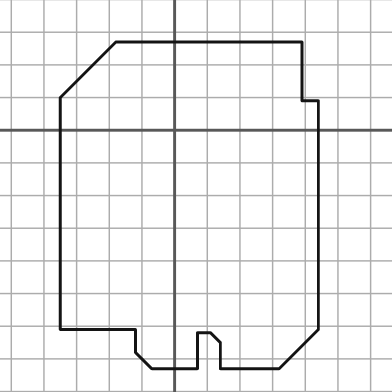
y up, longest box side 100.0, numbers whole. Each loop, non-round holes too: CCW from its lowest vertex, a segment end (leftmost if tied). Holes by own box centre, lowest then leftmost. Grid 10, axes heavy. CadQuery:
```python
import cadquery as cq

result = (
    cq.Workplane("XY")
    .moveTo(-7.0, -73.0)
    .lineTo(7.0, -73.0)
    .lineTo(7.0, -62.0)
    .lineTo(11.0, -62.0)
    .lineTo(14.0, -65.0)
    .lineTo(14.0, -73.0)
    .lineTo(32.0, -73.0)
    .lineTo(44.0, -61.0)
    .lineTo(44.0, 9.0)
    .lineTo(39.0, 9.0)
    .lineTo(39.0, 27.0)
    .lineTo(-18.0, 27.0)
    .lineTo(-35.0, 10.0)
    .lineTo(-35.0, -61.0)
    .lineTo(-12.0, -61.0)
    .lineTo(-12.0, -68.0)
    .close()
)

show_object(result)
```